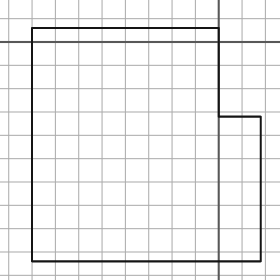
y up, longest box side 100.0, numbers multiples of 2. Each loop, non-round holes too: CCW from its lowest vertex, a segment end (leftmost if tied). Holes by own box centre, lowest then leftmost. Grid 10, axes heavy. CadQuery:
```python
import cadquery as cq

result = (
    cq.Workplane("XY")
    .moveTo(-80.0, -94.0)
    .lineTo(18.0, -94.0)
    .lineTo(18.0, -32.0)
    .lineTo(0.0, -32.0)
    .lineTo(0.0, 6.0)
    .lineTo(-80.0, 6.0)
    .close()
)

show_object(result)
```